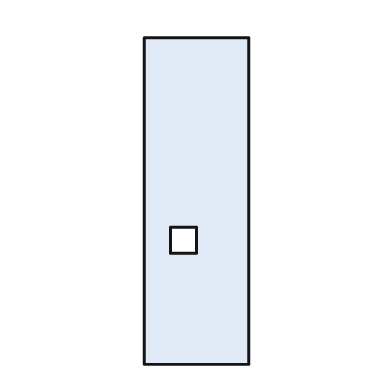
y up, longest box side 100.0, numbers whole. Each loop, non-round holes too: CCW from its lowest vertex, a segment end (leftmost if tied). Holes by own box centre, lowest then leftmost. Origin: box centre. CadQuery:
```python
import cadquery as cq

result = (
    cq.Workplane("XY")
    .moveTo(-16.0, -50.0)
    .lineTo(16.0, -50.0)
    .lineTo(16.0, 50.0)
    .lineTo(-16.0, 50.0)
    .close()
    .moveTo(-8.0, -16.0)
    .lineTo(0.0, -16.0)
    .lineTo(0.0, -8.0)
    .lineTo(-8.0, -8.0)
    .close()
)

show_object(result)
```